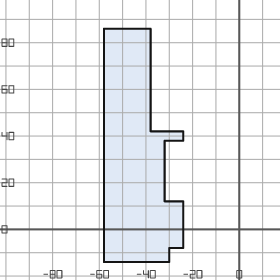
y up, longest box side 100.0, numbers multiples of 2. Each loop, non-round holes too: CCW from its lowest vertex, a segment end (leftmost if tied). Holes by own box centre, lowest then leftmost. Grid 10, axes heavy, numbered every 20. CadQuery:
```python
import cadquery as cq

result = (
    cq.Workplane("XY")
    .moveTo(-58.0, -14.0)
    .lineTo(-30.0, -14.0)
    .lineTo(-30.0, -8.0)
    .lineTo(-24.0, -8.0)
    .lineTo(-24.0, 12.0)
    .lineTo(-32.0, 12.0)
    .lineTo(-32.0, 38.0)
    .lineTo(-24.0, 38.0)
    .lineTo(-24.0, 42.0)
    .lineTo(-38.0, 42.0)
    .lineTo(-38.0, 86.0)
    .lineTo(-58.0, 86.0)
    .close()
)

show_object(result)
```